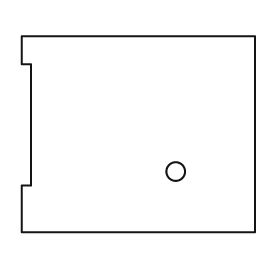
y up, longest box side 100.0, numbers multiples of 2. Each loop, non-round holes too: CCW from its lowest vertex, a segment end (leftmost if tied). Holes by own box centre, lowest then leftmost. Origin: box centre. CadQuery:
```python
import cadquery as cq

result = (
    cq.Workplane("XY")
    .moveTo(-50.0, -42.0)
    .lineTo(50.0, -42.0)
    .lineTo(50.0, 42.0)
    .lineTo(-50.0, 42.0)
    .lineTo(-50.0, 30.0)
    .lineTo(-46.0, 30.0)
    .lineTo(-46.0, -22.0)
    .lineTo(-50.0, -22.0)
    .close()
    .moveTo(16.0, -16.0)
    .circle(4.0)
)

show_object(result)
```